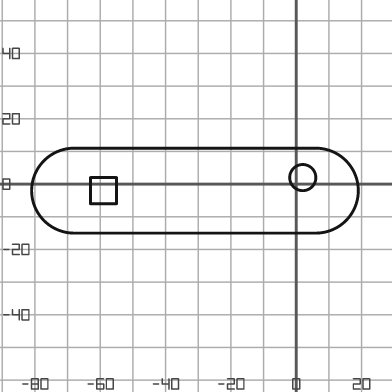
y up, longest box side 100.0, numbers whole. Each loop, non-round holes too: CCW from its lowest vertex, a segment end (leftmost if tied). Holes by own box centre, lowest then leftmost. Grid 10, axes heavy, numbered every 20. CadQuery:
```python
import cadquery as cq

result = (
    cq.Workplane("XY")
    .moveTo(-68.0, -15.0)
    .lineTo(6.0, -15.0)
    .threePointArc((19.0, -2.0), (6.0, 11.0))
    .lineTo(-68.0, 11.0)
    .threePointArc((-81.0, -2.0), (-68.0, -15.0))
    .close()
    .moveTo(-63.0, -6.0)
    .lineTo(-55.0, -6.0)
    .lineTo(-55.0, 2.0)
    .lineTo(-63.0, 2.0)
    .close()
    .moveTo(2.0, 2.0)
    .circle(4.0)
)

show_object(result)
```